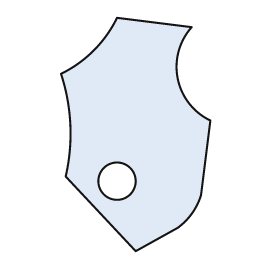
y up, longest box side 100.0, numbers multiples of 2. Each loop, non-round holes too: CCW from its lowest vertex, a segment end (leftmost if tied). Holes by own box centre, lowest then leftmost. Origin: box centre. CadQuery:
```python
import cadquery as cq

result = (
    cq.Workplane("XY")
    .moveTo(0.0, -50.0)
    .lineTo(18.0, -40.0)
    .threePointArc((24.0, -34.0), (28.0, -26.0))
    .lineTo(32.0, 6.0)
    .threePointArc((18.0, 24.0), (24.0, 46.0))
    .lineTo(-8.0, 50.0)
    .threePointArc((-18.0, 36.0), (-32.0, 26.0))
    .threePointArc((-28.0, 4.0), (-30.0, -18.0))
    .close()
    .moveTo(-8.0, -20.0)
    .circle(8.0)
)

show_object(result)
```